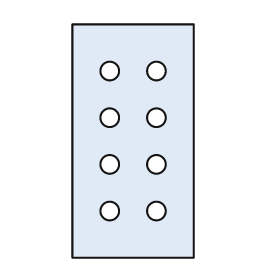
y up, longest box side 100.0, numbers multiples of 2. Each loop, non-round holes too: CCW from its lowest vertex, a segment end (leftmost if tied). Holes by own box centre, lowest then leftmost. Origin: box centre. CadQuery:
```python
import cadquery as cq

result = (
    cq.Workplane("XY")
    .moveTo(-26.0, -50.0)
    .lineTo(26.0, -50.0)
    .lineTo(26.0, 50.0)
    .lineTo(-26.0, 50.0)
    .close()
    .moveTo(-10.0, -30.0)
    .circle(4.0)
    .moveTo(10.0, -30.0)
    .circle(4.0)
    .moveTo(-10.0, -10.0)
    .circle(4.0)
    .moveTo(10.0, -10.0)
    .circle(4.0)
    .moveTo(-10.0, 10.0)
    .circle(4.0)
    .moveTo(10.0, 10.0)
    .circle(4.0)
    .moveTo(-10.0, 30.0)
    .circle(4.0)
    .moveTo(10.0, 30.0)
    .circle(4.0)
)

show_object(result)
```